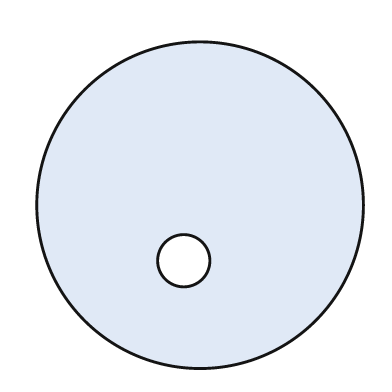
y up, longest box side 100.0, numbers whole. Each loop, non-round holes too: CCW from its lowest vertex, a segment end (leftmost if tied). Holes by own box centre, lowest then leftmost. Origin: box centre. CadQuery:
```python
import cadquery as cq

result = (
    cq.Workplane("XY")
    .moveTo(0.0, 0.0)
    .circle(50.0)
    .moveTo(-5.0, -17.0)
    .circle(8.0)
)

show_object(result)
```